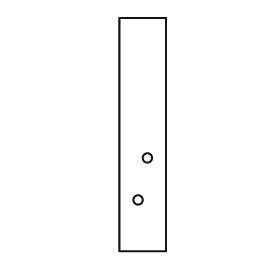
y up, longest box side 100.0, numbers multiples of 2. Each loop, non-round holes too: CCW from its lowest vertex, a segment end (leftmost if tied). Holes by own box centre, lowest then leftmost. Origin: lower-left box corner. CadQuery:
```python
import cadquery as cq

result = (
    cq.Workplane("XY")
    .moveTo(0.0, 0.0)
    .lineTo(20.0, 0.0)
    .lineTo(20.0, 100.0)
    .lineTo(0.0, 100.0)
    .close()
    .moveTo(8.0, 22.0)
    .circle(2.0)
    .moveTo(12.0, 40.0)
    .circle(2.0)
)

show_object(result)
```